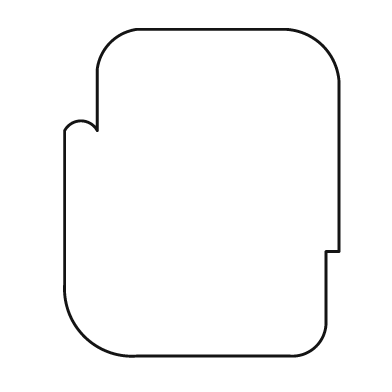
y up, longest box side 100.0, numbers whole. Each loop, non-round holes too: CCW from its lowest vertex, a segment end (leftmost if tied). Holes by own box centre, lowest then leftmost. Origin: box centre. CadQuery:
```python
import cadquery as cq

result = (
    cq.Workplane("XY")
    .moveTo(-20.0, -50.0)
    .lineTo(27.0, -50.0)
    .threePointArc((35.0, -47.0), (38.0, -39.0))
    .lineTo(38.0, -18.0)
    .lineTo(42.0, -18.0)
    .lineTo(42.0, 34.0)
    .threePointArc((37.0, 45.0), (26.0, 50.0))
    .lineTo(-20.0, 50.0)
    .threePointArc((-28.0, 46.0), (-32.0, 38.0))
    .lineTo(-32.0, 19.0)
    .threePointArc((-37.0, 22.0), (-42.0, 19.0))
    .lineTo(-42.0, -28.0)
    .threePointArc((-36.0, -44.0), (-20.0, -50.0))
    .close()
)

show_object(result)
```